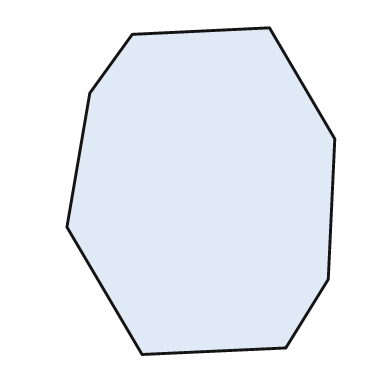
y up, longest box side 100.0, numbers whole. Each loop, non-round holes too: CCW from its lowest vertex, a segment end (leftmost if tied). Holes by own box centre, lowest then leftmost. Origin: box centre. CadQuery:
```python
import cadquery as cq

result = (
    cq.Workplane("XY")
    .moveTo(-18.0, -50.0)
    .lineTo(26.0, -48.0)
    .lineTo(39.0, -27.0)
    .lineTo(41.0, 16.0)
    .lineTo(21.0, 50.0)
    .lineTo(-21.0, 48.0)
    .lineTo(-34.0, 30.0)
    .lineTo(-41.0, -11.0)
    .close()
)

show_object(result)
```